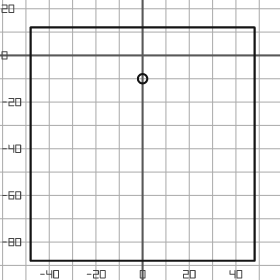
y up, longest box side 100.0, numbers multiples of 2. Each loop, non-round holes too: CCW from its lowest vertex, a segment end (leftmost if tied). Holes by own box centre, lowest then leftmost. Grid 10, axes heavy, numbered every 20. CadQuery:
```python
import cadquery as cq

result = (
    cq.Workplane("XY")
    .moveTo(-48.0, -88.0)
    .lineTo(48.0, -88.0)
    .lineTo(48.0, 12.0)
    .lineTo(-48.0, 12.0)
    .close()
    .moveTo(0.0, -10.0)
    .circle(2.0)
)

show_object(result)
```